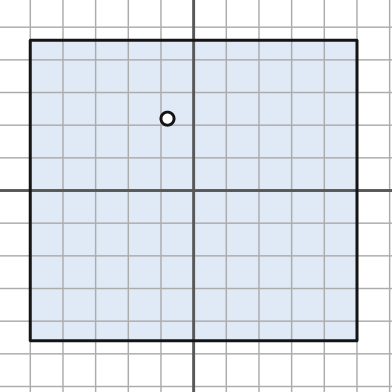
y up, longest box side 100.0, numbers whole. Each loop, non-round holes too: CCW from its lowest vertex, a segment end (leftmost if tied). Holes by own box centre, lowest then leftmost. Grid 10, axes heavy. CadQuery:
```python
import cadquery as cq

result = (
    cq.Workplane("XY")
    .moveTo(-50.0, -46.0)
    .lineTo(50.0, -46.0)
    .lineTo(50.0, 46.0)
    .lineTo(-50.0, 46.0)
    .close()
    .moveTo(-8.0, 22.0)
    .circle(2.0)
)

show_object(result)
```